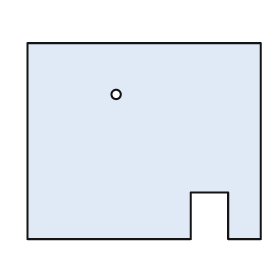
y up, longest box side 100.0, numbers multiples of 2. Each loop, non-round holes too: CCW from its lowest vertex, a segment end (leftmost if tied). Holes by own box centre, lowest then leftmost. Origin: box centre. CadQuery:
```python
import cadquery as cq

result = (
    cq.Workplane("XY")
    .moveTo(-50.0, -42.0)
    .lineTo(20.0, -42.0)
    .lineTo(20.0, -22.0)
    .lineTo(36.0, -22.0)
    .lineTo(36.0, -42.0)
    .lineTo(50.0, -42.0)
    .lineTo(50.0, 42.0)
    .lineTo(-50.0, 42.0)
    .close()
    .moveTo(-12.0, 20.0)
    .circle(2.0)
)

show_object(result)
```